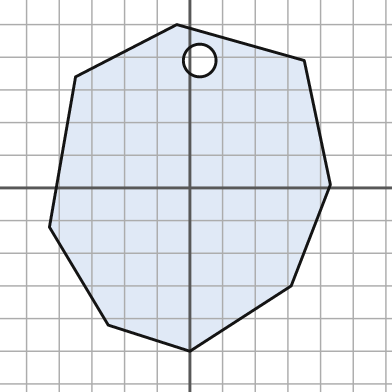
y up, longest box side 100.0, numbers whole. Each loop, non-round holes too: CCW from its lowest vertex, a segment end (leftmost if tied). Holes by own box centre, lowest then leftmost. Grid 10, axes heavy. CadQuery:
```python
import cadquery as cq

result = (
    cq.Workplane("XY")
    .moveTo(0.0, -50.0)
    .lineTo(31.0, -30.0)
    .lineTo(43.0, 1.0)
    .lineTo(35.0, 39.0)
    .lineTo(-4.0, 50.0)
    .lineTo(-35.0, 34.0)
    .lineTo(-43.0, -12.0)
    .lineTo(-25.0, -42.0)
    .close()
    .moveTo(3.0, 39.0)
    .circle(5.0)
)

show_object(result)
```